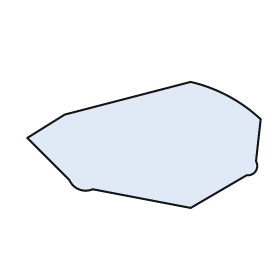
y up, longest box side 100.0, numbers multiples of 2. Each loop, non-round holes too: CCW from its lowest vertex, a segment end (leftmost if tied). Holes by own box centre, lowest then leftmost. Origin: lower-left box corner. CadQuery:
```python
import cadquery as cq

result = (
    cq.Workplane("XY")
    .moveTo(70.0, 0.0)
    .lineTo(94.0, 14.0)
    .threePointArc((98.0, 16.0), (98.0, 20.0))
    .lineTo(100.0, 38.0)
    .threePointArc((86.0, 48.0), (70.0, 54.0))
    .lineTo(16.0, 40.0)
    .lineTo(0.0, 30.0)
    .lineTo(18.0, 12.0)
    .threePointArc((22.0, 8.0), (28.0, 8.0))
    .close()
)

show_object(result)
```